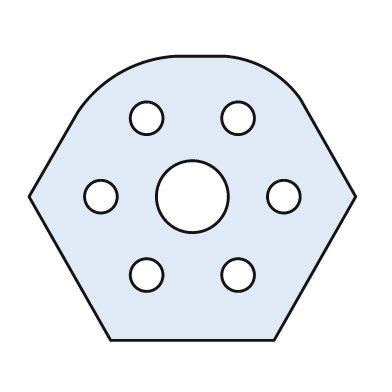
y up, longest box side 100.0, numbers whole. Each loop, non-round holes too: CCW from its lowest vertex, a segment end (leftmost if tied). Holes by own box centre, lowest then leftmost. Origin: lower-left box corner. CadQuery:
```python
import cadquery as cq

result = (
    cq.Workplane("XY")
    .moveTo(25.0, 0.0)
    .lineTo(75.0, 0.0)
    .lineTo(100.0, 44.0)
    .lineTo(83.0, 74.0)
    .threePointArc((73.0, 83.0), (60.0, 87.0))
    .lineTo(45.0, 87.0)
    .threePointArc((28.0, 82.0), (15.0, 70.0))
    .lineTo(0.0, 44.0)
    .close()
    .moveTo(36.0, 20.0)
    .circle(5.0)
    .moveTo(64.0, 20.0)
    .circle(5.0)
    .moveTo(22.0, 44.0)
    .circle(5.0)
    .moveTo(50.0, 44.0)
    .circle(11.0)
    .moveTo(78.0, 44.0)
    .circle(5.0)
    .moveTo(36.0, 68.0)
    .circle(5.0)
    .moveTo(64.0, 68.0)
    .circle(5.0)
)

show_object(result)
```